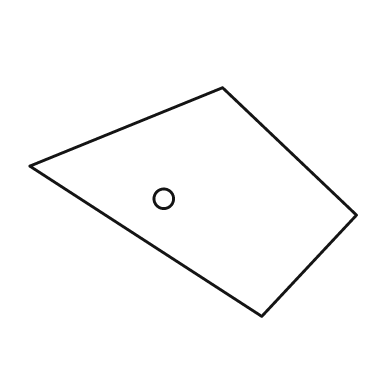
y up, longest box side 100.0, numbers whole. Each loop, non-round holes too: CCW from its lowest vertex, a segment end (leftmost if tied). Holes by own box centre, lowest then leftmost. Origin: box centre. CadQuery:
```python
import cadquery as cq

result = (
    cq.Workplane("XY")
    .moveTo(21.0, -35.0)
    .lineTo(50.0, -4.0)
    .lineTo(9.0, 35.0)
    .lineTo(-50.0, 11.0)
    .close()
    .moveTo(-9.0, 1.0)
    .circle(3.0)
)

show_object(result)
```